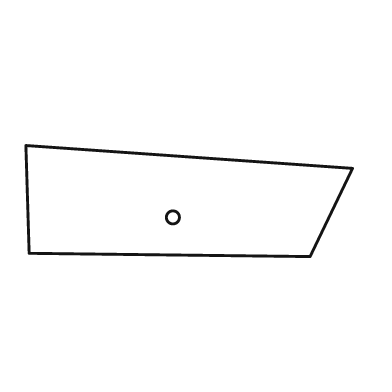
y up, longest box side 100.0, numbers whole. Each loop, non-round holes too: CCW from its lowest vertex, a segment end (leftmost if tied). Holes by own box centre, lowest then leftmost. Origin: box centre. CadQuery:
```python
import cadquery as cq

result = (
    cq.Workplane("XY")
    .moveTo(37.0, -17.0)
    .lineTo(50.0, 10.0)
    .lineTo(-50.0, 17.0)
    .lineTo(-49.0, -16.0)
    .close()
    .moveTo(-5.0, -5.0)
    .circle(2.0)
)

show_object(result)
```